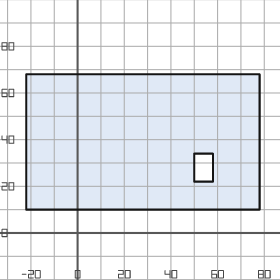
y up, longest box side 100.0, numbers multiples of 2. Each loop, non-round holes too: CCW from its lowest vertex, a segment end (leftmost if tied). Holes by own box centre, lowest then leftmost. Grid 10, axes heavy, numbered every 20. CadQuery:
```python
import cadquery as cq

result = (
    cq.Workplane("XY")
    .moveTo(-22.0, 10.0)
    .lineTo(78.0, 10.0)
    .lineTo(78.0, 68.0)
    .lineTo(-22.0, 68.0)
    .close()
    .moveTo(50.0, 22.0)
    .lineTo(58.0, 22.0)
    .lineTo(58.0, 34.0)
    .lineTo(50.0, 34.0)
    .close()
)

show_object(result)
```